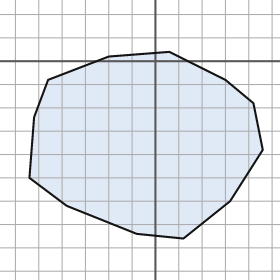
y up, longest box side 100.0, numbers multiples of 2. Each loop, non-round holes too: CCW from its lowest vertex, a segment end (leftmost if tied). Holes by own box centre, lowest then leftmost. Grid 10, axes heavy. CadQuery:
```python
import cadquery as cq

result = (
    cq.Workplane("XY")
    .moveTo(12.0, -76.0)
    .lineTo(32.0, -60.0)
    .lineTo(46.0, -38.0)
    .lineTo(42.0, -18.0)
    .lineTo(30.0, -8.0)
    .lineTo(6.0, 4.0)
    .lineTo(-20.0, 2.0)
    .lineTo(-46.0, -8.0)
    .lineTo(-52.0, -24.0)
    .lineTo(-54.0, -50.0)
    .lineTo(-38.0, -62.0)
    .lineTo(-8.0, -74.0)
    .close()
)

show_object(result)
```